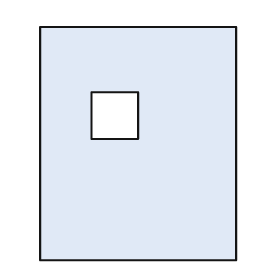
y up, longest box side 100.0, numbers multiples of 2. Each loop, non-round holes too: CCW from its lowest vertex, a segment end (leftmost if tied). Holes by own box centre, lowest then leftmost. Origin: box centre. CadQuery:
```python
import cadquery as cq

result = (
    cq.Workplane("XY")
    .moveTo(-42.0, -50.0)
    .lineTo(42.0, -50.0)
    .lineTo(42.0, 50.0)
    .lineTo(-42.0, 50.0)
    .close()
    .moveTo(-20.0, 2.0)
    .lineTo(0.0, 2.0)
    .lineTo(0.0, 22.0)
    .lineTo(-20.0, 22.0)
    .close()
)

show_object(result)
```